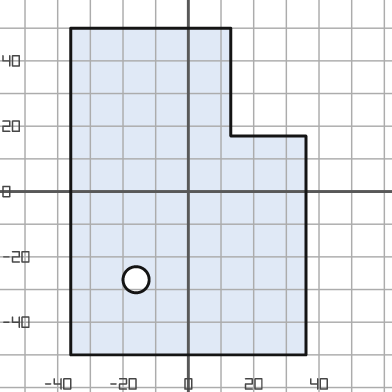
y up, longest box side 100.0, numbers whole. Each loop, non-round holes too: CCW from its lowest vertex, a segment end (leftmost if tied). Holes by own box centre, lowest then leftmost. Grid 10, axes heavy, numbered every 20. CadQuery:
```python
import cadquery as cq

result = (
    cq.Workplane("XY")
    .moveTo(-36.0, -50.0)
    .lineTo(36.0, -50.0)
    .lineTo(36.0, 17.0)
    .lineTo(13.0, 17.0)
    .lineTo(13.0, 50.0)
    .lineTo(-36.0, 50.0)
    .close()
    .moveTo(-16.0, -27.0)
    .circle(4.0)
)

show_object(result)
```